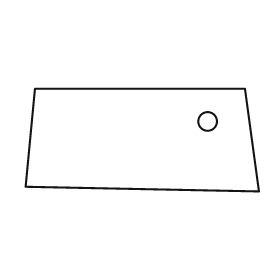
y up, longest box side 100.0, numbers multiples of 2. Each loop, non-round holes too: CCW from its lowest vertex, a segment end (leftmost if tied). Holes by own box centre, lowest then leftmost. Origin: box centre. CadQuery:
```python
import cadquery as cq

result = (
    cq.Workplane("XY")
    .moveTo(50.0, -22.0)
    .lineTo(44.0, 22.0)
    .lineTo(-46.0, 22.0)
    .lineTo(-50.0, -20.0)
    .close()
    .moveTo(28.0, 8.0)
    .circle(4.0)
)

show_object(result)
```